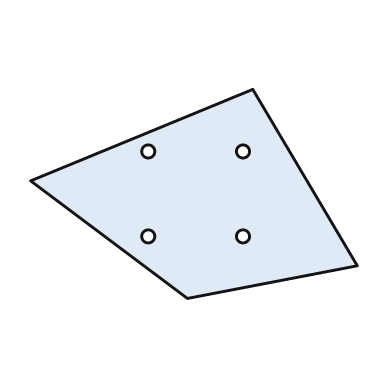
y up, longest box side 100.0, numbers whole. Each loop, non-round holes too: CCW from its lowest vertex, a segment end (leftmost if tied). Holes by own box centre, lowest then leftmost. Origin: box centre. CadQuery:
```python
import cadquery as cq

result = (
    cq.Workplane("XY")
    .moveTo(-2.0, -32.0)
    .lineTo(50.0, -22.0)
    .lineTo(18.0, 32.0)
    .lineTo(-50.0, 4.0)
    .close()
    .moveTo(-14.0, -13.0)
    .circle(2.0)
    .moveTo(15.0, -13.0)
    .circle(2.0)
    .moveTo(-14.0, 13.0)
    .circle(2.0)
    .moveTo(15.0, 13.0)
    .circle(2.0)
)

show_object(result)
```